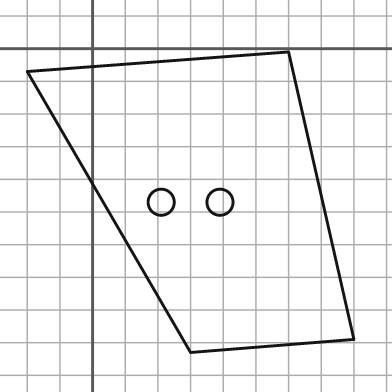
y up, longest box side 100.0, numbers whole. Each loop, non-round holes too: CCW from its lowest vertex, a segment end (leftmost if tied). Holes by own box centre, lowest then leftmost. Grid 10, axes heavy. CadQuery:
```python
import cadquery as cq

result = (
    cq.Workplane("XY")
    .moveTo(30.0, -93.0)
    .lineTo(80.0, -89.0)
    .lineTo(60.0, -1.0)
    .lineTo(-20.0, -7.0)
    .close()
    .moveTo(21.0, -47.0)
    .circle(4.0)
    .moveTo(39.0, -47.0)
    .circle(4.0)
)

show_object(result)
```